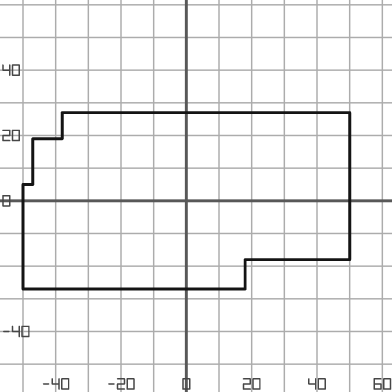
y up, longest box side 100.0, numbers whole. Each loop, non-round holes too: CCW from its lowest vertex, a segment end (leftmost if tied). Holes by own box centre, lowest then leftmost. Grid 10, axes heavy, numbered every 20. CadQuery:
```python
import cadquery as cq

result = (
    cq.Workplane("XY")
    .moveTo(-50.0, -27.0)
    .lineTo(18.0, -27.0)
    .lineTo(18.0, -18.0)
    .lineTo(50.0, -18.0)
    .lineTo(50.0, 27.0)
    .lineTo(-38.0, 27.0)
    .lineTo(-38.0, 19.0)
    .lineTo(-47.0, 19.0)
    .lineTo(-47.0, 5.0)
    .lineTo(-50.0, 5.0)
    .close()
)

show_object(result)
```